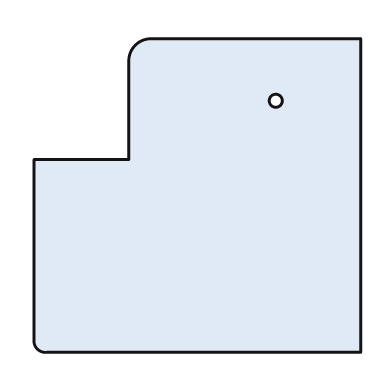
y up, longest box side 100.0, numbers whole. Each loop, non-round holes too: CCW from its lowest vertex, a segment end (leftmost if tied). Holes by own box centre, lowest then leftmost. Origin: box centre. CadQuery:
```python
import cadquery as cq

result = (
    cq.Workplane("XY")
    .moveTo(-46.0, -48.0)
    .lineTo(50.0, -48.0)
    .lineTo(50.0, 48.0)
    .lineTo(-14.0, 48.0)
    .threePointArc((-19.0, 46.0), (-21.0, 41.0))
    .lineTo(-21.0, 11.0)
    .lineTo(-50.0, 11.0)
    .lineTo(-50.0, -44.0)
    .threePointArc((-49.0, -47.0), (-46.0, -48.0))
    .close()
    .moveTo(24.0, 29.0)
    .circle(2.0)
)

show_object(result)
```